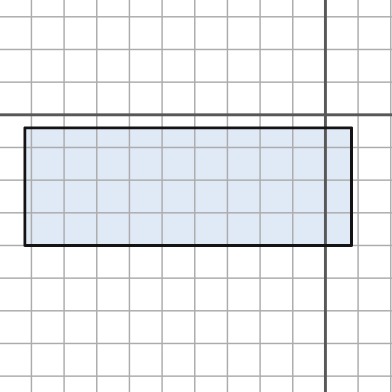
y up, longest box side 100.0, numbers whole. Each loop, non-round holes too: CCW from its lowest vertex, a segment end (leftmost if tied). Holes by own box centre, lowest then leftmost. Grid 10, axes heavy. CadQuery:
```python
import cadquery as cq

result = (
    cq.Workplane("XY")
    .moveTo(-92.0, -40.0)
    .lineTo(8.0, -40.0)
    .lineTo(8.0, -4.0)
    .lineTo(-92.0, -4.0)
    .close()
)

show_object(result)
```